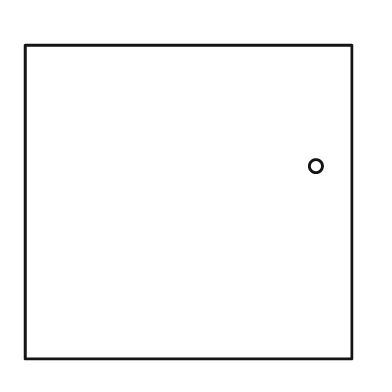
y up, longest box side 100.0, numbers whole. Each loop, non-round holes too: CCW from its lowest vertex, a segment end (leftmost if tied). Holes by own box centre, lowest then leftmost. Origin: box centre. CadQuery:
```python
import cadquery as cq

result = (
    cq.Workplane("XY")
    .moveTo(-50.0, -48.0)
    .lineTo(50.0, -48.0)
    .lineTo(50.0, 48.0)
    .lineTo(-50.0, 48.0)
    .close()
    .moveTo(39.0, 11.0)
    .circle(2.0)
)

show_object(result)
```